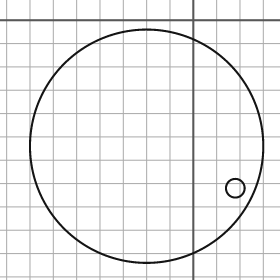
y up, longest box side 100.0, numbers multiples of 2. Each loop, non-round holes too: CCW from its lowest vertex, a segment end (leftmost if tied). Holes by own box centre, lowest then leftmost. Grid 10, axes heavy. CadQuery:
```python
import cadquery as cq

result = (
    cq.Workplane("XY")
    .moveTo(-20.0, -54.0)
    .circle(50.0)
    .moveTo(18.0, -72.0)
    .circle(4.0)
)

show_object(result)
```